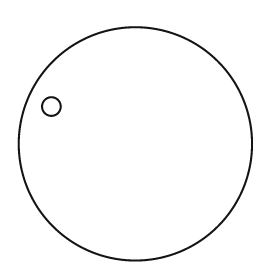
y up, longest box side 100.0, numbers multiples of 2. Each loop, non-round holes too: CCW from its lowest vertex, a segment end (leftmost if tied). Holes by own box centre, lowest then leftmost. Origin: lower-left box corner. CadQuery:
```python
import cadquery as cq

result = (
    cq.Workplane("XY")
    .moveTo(50.0, 50.0)
    .circle(50.0)
    .moveTo(14.0, 66.0)
    .circle(4.0)
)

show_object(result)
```